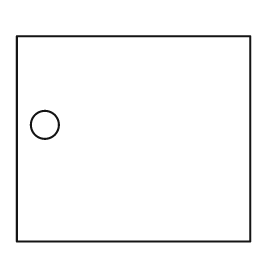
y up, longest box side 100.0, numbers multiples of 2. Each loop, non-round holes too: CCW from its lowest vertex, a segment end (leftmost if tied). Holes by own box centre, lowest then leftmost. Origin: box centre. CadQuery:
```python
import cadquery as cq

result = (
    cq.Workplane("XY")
    .moveTo(-50.0, -44.0)
    .lineTo(50.0, -44.0)
    .lineTo(50.0, 44.0)
    .lineTo(-50.0, 44.0)
    .close()
    .moveTo(-38.0, 6.0)
    .circle(6.0)
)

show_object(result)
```